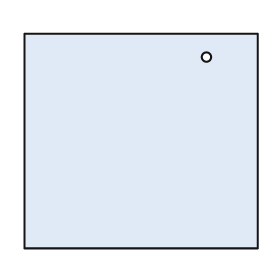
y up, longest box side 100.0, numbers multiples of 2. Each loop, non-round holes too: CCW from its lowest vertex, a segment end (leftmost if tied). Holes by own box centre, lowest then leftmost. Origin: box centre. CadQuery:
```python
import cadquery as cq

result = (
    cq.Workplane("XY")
    .moveTo(-50.0, -46.0)
    .lineTo(50.0, -46.0)
    .lineTo(50.0, 46.0)
    .lineTo(-50.0, 46.0)
    .close()
    .moveTo(28.0, 36.0)
    .circle(2.0)
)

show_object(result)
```